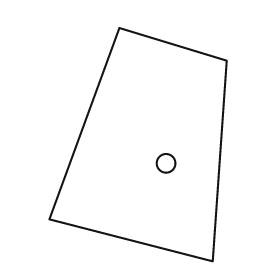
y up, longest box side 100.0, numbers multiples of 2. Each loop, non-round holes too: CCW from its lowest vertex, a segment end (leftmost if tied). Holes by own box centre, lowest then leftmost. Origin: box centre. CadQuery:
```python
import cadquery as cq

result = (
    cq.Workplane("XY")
    .moveTo(32.0, -50.0)
    .lineTo(38.0, 36.0)
    .lineTo(-8.0, 50.0)
    .lineTo(-38.0, -32.0)
    .close()
    .moveTo(12.0, -8.0)
    .circle(4.0)
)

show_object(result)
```